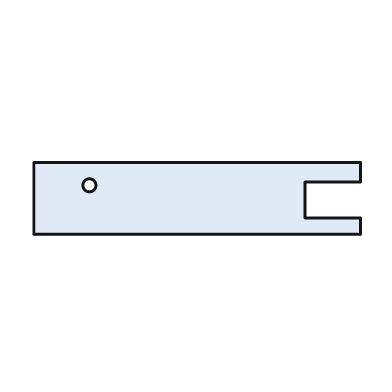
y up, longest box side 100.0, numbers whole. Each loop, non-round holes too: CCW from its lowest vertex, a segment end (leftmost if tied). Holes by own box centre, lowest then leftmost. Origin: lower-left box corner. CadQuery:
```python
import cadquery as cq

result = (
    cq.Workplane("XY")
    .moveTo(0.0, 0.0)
    .lineTo(100.0, 0.0)
    .lineTo(100.0, 5.0)
    .lineTo(83.0, 5.0)
    .lineTo(83.0, 16.0)
    .lineTo(100.0, 16.0)
    .lineTo(100.0, 22.0)
    .lineTo(0.0, 22.0)
    .close()
    .moveTo(17.0, 15.0)
    .circle(2.0)
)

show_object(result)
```